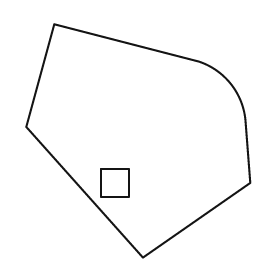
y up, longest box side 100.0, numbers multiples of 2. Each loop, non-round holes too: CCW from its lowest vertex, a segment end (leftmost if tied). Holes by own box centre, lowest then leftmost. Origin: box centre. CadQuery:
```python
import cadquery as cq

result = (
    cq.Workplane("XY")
    .moveTo(2.0, -50.0)
    .lineTo(48.0, -18.0)
    .lineTo(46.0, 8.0)
    .threePointArc((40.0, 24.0), (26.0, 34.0))
    .lineTo(-36.0, 50.0)
    .lineTo(-48.0, 6.0)
    .close()
    .moveTo(-16.0, -24.0)
    .lineTo(-4.0, -24.0)
    .lineTo(-4.0, -12.0)
    .lineTo(-16.0, -12.0)
    .close()
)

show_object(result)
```